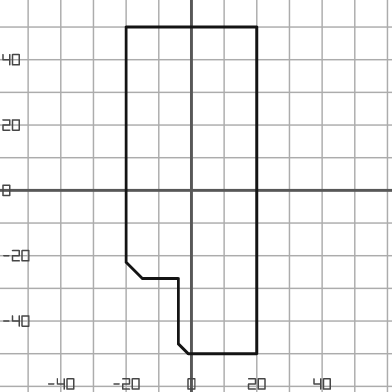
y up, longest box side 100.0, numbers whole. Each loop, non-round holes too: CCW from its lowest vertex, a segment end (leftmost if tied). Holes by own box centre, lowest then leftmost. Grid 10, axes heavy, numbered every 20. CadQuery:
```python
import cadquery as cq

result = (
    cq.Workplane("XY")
    .moveTo(-1.0, -50.0)
    .lineTo(20.0, -50.0)
    .lineTo(20.0, 50.0)
    .lineTo(-20.0, 50.0)
    .lineTo(-20.0, -22.0)
    .lineTo(-15.0, -27.0)
    .lineTo(-4.0, -27.0)
    .lineTo(-4.0, -47.0)
    .close()
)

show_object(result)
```